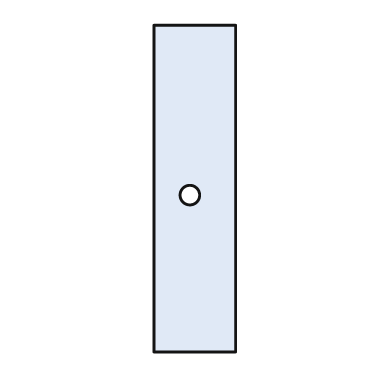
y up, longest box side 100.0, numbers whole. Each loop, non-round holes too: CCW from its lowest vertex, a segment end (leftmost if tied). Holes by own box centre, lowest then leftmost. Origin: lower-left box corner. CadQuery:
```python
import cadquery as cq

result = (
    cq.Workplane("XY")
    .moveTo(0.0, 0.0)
    .lineTo(25.0, 0.0)
    .lineTo(25.0, 100.0)
    .lineTo(0.0, 100.0)
    .close()
    .moveTo(11.0, 48.0)
    .circle(3.0)
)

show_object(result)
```